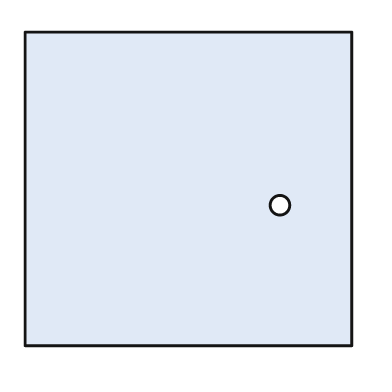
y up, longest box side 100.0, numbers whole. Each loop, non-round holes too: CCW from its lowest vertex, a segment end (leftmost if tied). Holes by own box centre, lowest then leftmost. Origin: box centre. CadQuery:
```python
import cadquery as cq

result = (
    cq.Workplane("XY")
    .moveTo(-50.0, -48.0)
    .lineTo(50.0, -48.0)
    .lineTo(50.0, 48.0)
    .lineTo(-50.0, 48.0)
    .close()
    .moveTo(28.0, -5.0)
    .circle(3.0)
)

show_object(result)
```